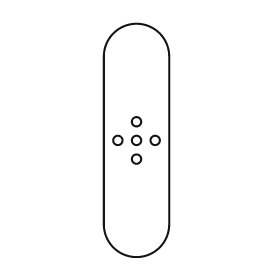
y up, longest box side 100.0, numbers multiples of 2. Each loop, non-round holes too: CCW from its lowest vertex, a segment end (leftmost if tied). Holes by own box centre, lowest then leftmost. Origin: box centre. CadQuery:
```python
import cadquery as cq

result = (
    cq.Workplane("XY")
    .moveTo(-14.0, -36.0)
    .threePointArc((0.0, -50.0), (14.0, -36.0))
    .lineTo(14.0, 36.0)
    .threePointArc((0.0, 50.0), (-14.0, 36.0))
    .close()
    .moveTo(0.0, -8.0)
    .circle(2.0)
    .moveTo(-8.0, 0.0)
    .circle(2.0)
    .moveTo(0.0, 0.0)
    .circle(2.0)
    .moveTo(8.0, 0.0)
    .circle(2.0)
    .moveTo(0.0, 8.0)
    .circle(2.0)
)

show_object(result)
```